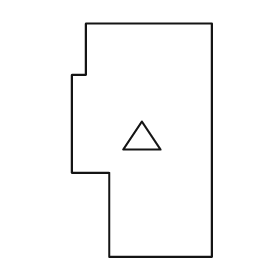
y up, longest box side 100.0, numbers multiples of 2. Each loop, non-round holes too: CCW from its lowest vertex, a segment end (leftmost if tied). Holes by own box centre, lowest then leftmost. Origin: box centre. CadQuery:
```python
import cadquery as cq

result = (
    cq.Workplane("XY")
    .moveTo(-14.0, -50.0)
    .lineTo(30.0, -50.0)
    .lineTo(30.0, 50.0)
    .lineTo(-24.0, 50.0)
    .lineTo(-24.0, 28.0)
    .lineTo(-30.0, 28.0)
    .lineTo(-30.0, -14.0)
    .lineTo(-14.0, -14.0)
    .close()
    .moveTo(-8.0, -4.0)
    .lineTo(8.0, -4.0)
    .lineTo(0.0, 8.0)
    .close()
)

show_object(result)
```